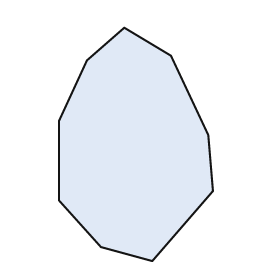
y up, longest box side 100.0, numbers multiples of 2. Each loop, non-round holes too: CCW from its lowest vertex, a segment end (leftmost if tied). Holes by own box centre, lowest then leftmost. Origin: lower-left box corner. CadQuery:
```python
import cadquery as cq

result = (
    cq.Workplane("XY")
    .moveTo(40.0, 0.0)
    .lineTo(66.0, 30.0)
    .lineTo(64.0, 54.0)
    .lineTo(48.0, 88.0)
    .lineTo(28.0, 100.0)
    .lineTo(12.0, 86.0)
    .lineTo(0.0, 60.0)
    .lineTo(0.0, 26.0)
    .lineTo(18.0, 6.0)
    .close()
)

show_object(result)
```